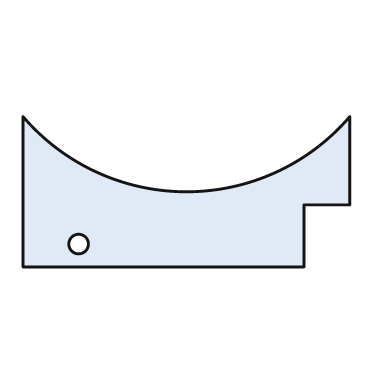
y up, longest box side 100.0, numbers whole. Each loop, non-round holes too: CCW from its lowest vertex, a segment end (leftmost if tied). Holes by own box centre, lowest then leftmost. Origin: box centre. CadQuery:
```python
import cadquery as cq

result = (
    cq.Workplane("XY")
    .moveTo(-50.0, -23.0)
    .lineTo(36.0, -23.0)
    .lineTo(36.0, -4.0)
    .lineTo(50.0, -4.0)
    .lineTo(50.0, 23.0)
    .threePointArc((0.0, 0.0), (-50.0, 23.0))
    .close()
    .moveTo(-33.0, -16.0)
    .circle(3.0)
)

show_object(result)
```